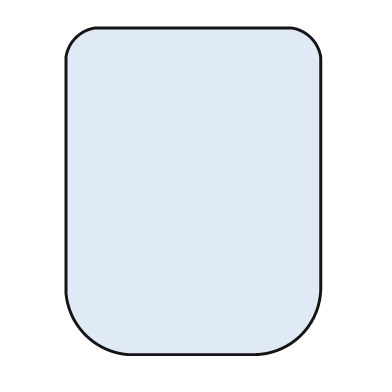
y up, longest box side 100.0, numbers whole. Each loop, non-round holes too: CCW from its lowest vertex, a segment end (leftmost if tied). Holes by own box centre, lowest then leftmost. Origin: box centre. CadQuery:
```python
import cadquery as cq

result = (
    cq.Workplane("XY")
    .moveTo(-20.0, -50.0)
    .lineTo(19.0, -50.0)
    .threePointArc((33.0, -44.0), (39.0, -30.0))
    .lineTo(39.0, 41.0)
    .threePointArc((36.0, 47.0), (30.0, 50.0))
    .lineTo(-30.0, 50.0)
    .threePointArc((-36.0, 47.0), (-39.0, 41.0))
    .lineTo(-39.0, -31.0)
    .threePointArc((-33.0, -44.0), (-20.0, -50.0))
    .close()
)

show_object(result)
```